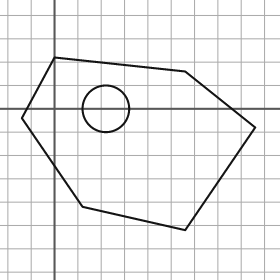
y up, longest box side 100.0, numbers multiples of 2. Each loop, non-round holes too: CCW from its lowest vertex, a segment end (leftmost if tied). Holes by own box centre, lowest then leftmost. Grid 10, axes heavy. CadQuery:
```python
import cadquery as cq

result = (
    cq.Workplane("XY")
    .moveTo(56.0, -52.0)
    .lineTo(86.0, -8.0)
    .lineTo(56.0, 16.0)
    .lineTo(0.0, 22.0)
    .lineTo(-14.0, -4.0)
    .lineTo(12.0, -42.0)
    .close()
    .moveTo(22.0, 0.0)
    .circle(10.0)
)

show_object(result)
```